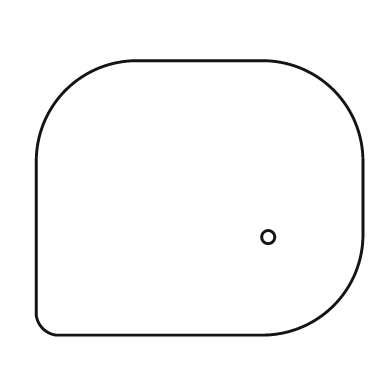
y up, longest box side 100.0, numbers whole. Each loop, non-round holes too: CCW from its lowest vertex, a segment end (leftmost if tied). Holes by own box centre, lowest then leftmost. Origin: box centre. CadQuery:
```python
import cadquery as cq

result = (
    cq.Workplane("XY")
    .moveTo(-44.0, -42.0)
    .lineTo(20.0, -42.0)
    .threePointArc((41.0, -33.0), (50.0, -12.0))
    .lineTo(50.0, 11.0)
    .threePointArc((41.0, 33.0), (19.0, 42.0))
    .lineTo(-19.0, 42.0)
    .threePointArc((-41.0, 33.0), (-50.0, 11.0))
    .lineTo(-50.0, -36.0)
    .threePointArc((-48.0, -40.0), (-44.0, -42.0))
    .close()
    .moveTo(21.0, -12.0)
    .circle(2.0)
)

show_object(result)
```